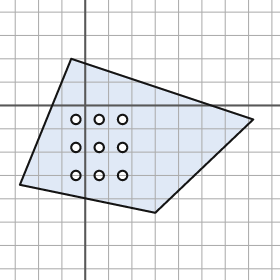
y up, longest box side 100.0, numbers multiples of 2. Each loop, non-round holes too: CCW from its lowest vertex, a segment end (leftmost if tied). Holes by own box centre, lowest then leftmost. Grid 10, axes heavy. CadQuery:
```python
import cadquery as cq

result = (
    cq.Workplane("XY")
    .moveTo(30.0, -46.0)
    .lineTo(72.0, -6.0)
    .lineTo(-6.0, 20.0)
    .lineTo(-28.0, -34.0)
    .close()
    .moveTo(-4.0, -30.0)
    .circle(2.0)
    .moveTo(6.0, -30.0)
    .circle(2.0)
    .moveTo(16.0, -30.0)
    .circle(2.0)
    .moveTo(-4.0, -18.0)
    .circle(2.0)
    .moveTo(6.0, -18.0)
    .circle(2.0)
    .moveTo(16.0, -18.0)
    .circle(2.0)
    .moveTo(-4.0, -6.0)
    .circle(2.0)
    .moveTo(6.0, -6.0)
    .circle(2.0)
    .moveTo(16.0, -6.0)
    .circle(2.0)
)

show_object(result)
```